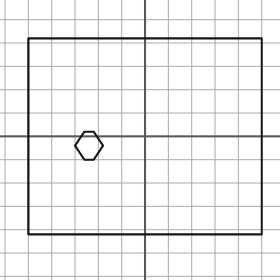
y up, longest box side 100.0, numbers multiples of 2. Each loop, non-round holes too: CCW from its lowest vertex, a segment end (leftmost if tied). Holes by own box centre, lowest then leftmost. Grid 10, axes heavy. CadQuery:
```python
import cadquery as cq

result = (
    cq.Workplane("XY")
    .moveTo(-50.0, -42.0)
    .lineTo(50.0, -42.0)
    .lineTo(50.0, 42.0)
    .lineTo(-50.0, 42.0)
    .close()
    .moveTo(-26.0, -10.0)
    .lineTo(-22.0, -10.0)
    .lineTo(-18.0, -4.0)
    .lineTo(-22.0, 2.0)
    .lineTo(-26.0, 2.0)
    .lineTo(-30.0, -4.0)
    .close()
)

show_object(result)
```